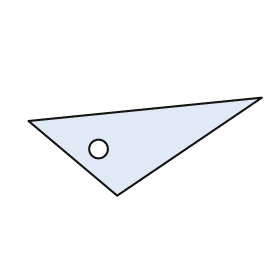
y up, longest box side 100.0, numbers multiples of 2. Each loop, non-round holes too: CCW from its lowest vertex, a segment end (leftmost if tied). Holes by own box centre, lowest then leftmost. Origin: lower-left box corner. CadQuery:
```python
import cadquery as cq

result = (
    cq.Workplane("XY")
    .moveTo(38.0, 0.0)
    .lineTo(100.0, 42.0)
    .lineTo(0.0, 32.0)
    .close()
    .moveTo(30.0, 20.0)
    .circle(4.0)
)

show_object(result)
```